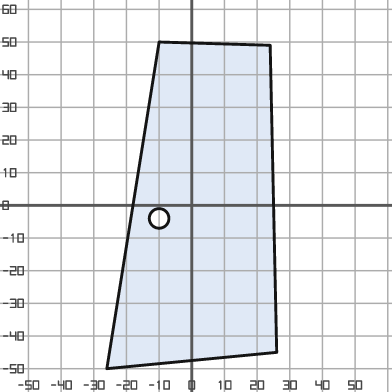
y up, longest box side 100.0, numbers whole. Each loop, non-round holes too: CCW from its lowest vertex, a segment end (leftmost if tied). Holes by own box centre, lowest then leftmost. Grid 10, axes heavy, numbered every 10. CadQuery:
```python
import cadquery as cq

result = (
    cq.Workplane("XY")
    .moveTo(-26.0, -50.0)
    .lineTo(26.0, -45.0)
    .lineTo(24.0, 49.0)
    .lineTo(-10.0, 50.0)
    .close()
    .moveTo(-10.0, -4.0)
    .circle(3.0)
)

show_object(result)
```